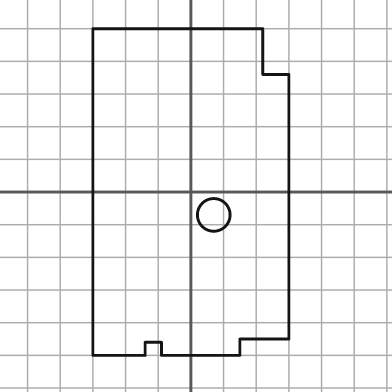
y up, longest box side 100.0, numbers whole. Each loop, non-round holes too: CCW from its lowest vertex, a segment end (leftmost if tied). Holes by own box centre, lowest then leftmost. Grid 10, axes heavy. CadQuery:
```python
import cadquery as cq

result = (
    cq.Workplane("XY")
    .moveTo(-30.0, -50.0)
    .lineTo(-14.0, -50.0)
    .lineTo(-14.0, -46.0)
    .lineTo(-9.0, -46.0)
    .lineTo(-9.0, -50.0)
    .lineTo(15.0, -50.0)
    .lineTo(15.0, -45.0)
    .lineTo(30.0, -45.0)
    .lineTo(30.0, 36.0)
    .lineTo(22.0, 36.0)
    .lineTo(22.0, 50.0)
    .lineTo(-30.0, 50.0)
    .close()
    .moveTo(7.0, -7.0)
    .circle(5.0)
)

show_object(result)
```